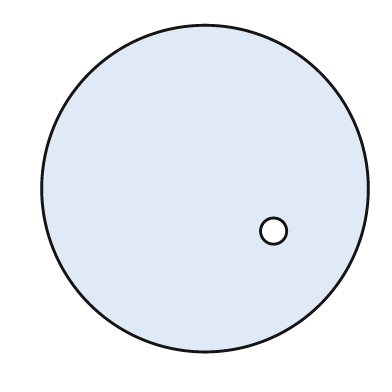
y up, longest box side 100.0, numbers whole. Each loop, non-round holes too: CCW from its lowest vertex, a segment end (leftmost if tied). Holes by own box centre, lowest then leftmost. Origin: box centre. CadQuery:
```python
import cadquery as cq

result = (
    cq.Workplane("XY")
    .moveTo(0.0, 0.0)
    .circle(50.0)
    .moveTo(21.0, -13.0)
    .circle(4.0)
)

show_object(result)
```